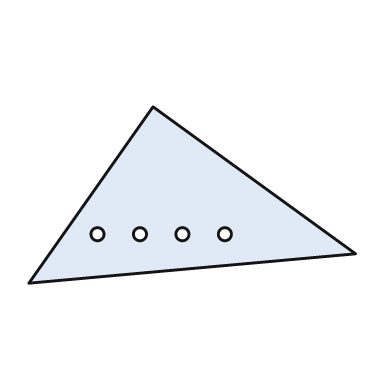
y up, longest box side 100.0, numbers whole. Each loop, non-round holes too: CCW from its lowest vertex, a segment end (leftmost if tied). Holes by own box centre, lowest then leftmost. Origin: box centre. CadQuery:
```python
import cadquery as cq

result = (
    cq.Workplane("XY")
    .moveTo(-50.0, -27.0)
    .lineTo(50.0, -18.0)
    .lineTo(-12.0, 27.0)
    .close()
    .moveTo(-29.0, -12.0)
    .circle(2.0)
    .moveTo(-16.0, -12.0)
    .circle(2.0)
    .moveTo(-3.0, -12.0)
    .circle(2.0)
    .moveTo(10.0, -12.0)
    .circle(2.0)
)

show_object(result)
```